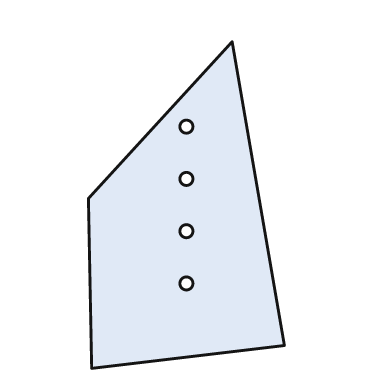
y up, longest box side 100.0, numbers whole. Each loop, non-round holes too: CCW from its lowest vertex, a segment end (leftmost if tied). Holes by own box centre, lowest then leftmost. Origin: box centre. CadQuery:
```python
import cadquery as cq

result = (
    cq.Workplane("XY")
    .moveTo(-29.0, -50.0)
    .lineTo(30.0, -43.0)
    .lineTo(14.0, 50.0)
    .lineTo(-30.0, 2.0)
    .close()
    .moveTo(0.0, -24.0)
    .circle(2.0)
    .moveTo(0.0, -8.0)
    .circle(2.0)
    .moveTo(0.0, 8.0)
    .circle(2.0)
    .moveTo(0.0, 24.0)
    .circle(2.0)
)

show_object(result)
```